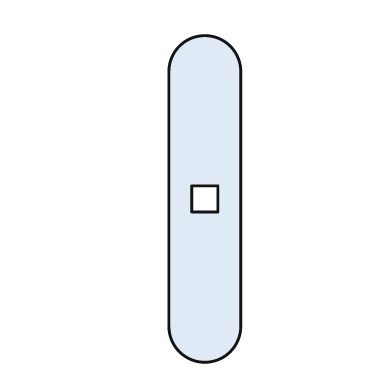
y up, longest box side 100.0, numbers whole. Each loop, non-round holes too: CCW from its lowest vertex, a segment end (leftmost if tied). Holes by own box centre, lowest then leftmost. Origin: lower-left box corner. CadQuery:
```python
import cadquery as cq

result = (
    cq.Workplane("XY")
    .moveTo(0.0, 11.0)
    .threePointArc((11.0, 0.0), (22.0, 11.0))
    .lineTo(22.0, 89.0)
    .threePointArc((11.0, 100.0), (0.0, 89.0))
    .close()
    .moveTo(7.0, 46.0)
    .lineTo(15.0, 46.0)
    .lineTo(15.0, 54.0)
    .lineTo(7.0, 54.0)
    .close()
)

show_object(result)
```